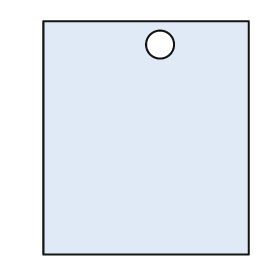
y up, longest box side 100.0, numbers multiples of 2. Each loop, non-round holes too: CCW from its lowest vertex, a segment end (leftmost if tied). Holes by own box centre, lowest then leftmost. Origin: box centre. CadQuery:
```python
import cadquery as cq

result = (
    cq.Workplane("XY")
    .moveTo(-44.0, -50.0)
    .lineTo(44.0, -50.0)
    .lineTo(44.0, 50.0)
    .lineTo(-44.0, 50.0)
    .close()
    .moveTo(6.0, 40.0)
    .circle(6.0)
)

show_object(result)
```